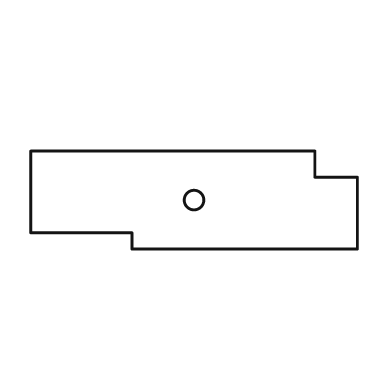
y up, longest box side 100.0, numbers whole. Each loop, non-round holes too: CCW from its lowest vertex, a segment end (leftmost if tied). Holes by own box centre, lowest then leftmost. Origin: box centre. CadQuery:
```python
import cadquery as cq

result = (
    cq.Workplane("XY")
    .moveTo(-19.0, -15.0)
    .lineTo(50.0, -15.0)
    .lineTo(50.0, 7.0)
    .lineTo(37.0, 7.0)
    .lineTo(37.0, 15.0)
    .lineTo(-50.0, 15.0)
    .lineTo(-50.0, -10.0)
    .lineTo(-19.0, -10.0)
    .close()
    .moveTo(0.0, 0.0)
    .circle(3.0)
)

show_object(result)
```